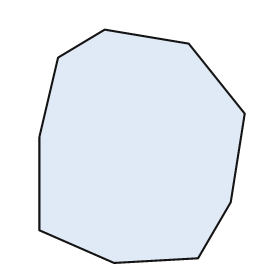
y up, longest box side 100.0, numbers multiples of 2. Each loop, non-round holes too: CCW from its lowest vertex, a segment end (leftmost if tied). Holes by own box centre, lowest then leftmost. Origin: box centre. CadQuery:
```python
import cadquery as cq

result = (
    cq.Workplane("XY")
    .moveTo(-12.0, -50.0)
    .lineTo(24.0, -48.0)
    .lineTo(38.0, -24.0)
    .lineTo(44.0, 14.0)
    .lineTo(20.0, 44.0)
    .lineTo(-16.0, 50.0)
    .lineTo(-36.0, 38.0)
    .lineTo(-44.0, 4.0)
    .lineTo(-44.0, -36.0)
    .close()
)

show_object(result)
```